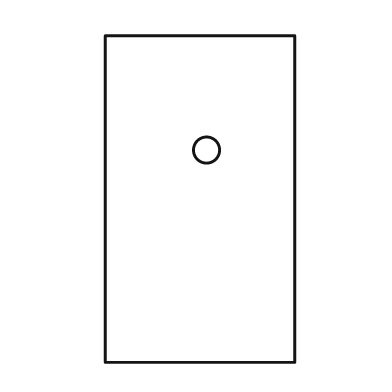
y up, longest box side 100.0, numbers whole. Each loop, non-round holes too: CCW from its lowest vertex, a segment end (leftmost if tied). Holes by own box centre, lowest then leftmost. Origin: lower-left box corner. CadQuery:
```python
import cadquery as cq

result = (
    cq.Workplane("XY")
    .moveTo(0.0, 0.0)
    .lineTo(58.0, 0.0)
    .lineTo(58.0, 100.0)
    .lineTo(0.0, 100.0)
    .close()
    .moveTo(31.0, 65.0)
    .circle(4.0)
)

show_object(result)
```